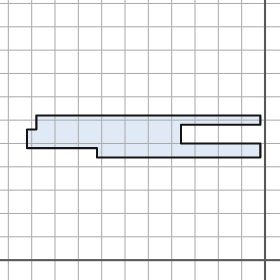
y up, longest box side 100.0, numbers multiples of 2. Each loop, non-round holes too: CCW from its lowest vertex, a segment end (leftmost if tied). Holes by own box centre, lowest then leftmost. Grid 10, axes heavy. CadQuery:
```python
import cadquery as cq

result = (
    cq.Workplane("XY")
    .moveTo(-72.0, 44.0)
    .lineTo(-2.0, 44.0)
    .lineTo(-2.0, 50.0)
    .lineTo(-36.0, 50.0)
    .lineTo(-36.0, 58.0)
    .lineTo(-2.0, 58.0)
    .lineTo(-2.0, 62.0)
    .lineTo(-98.0, 62.0)
    .lineTo(-98.0, 56.0)
    .lineTo(-102.0, 56.0)
    .lineTo(-102.0, 48.0)
    .lineTo(-72.0, 48.0)
    .close()
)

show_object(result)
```